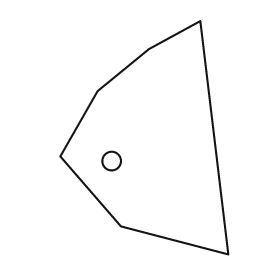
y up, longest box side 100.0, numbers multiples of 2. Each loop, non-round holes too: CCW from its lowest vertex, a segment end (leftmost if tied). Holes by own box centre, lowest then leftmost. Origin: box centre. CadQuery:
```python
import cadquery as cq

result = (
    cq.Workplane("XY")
    .moveTo(36.0, -50.0)
    .lineTo(24.0, 50.0)
    .lineTo(2.0, 38.0)
    .lineTo(-20.0, 20.0)
    .lineTo(-36.0, -8.0)
    .lineTo(-10.0, -38.0)
    .close()
    .moveTo(-14.0, -10.0)
    .circle(4.0)
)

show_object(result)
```